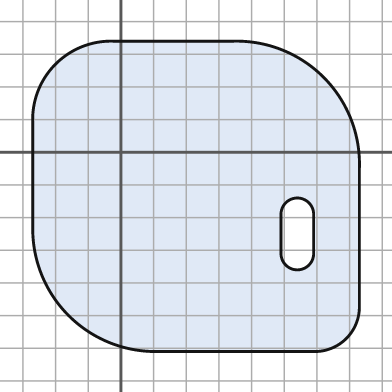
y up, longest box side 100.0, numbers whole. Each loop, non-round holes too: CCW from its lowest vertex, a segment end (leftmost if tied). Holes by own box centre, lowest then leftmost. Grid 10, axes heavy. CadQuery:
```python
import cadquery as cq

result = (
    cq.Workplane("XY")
    .moveTo(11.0, -61.0)
    .lineTo(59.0, -61.0)
    .threePointArc((69.0, -57.0), (73.0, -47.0))
    .lineTo(73.0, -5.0)
    .threePointArc((62.0, 23.0), (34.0, 34.0))
    .lineTo(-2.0, 34.0)
    .threePointArc((-20.0, 27.0), (-27.0, 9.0))
    .lineTo(-27.0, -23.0)
    .threePointArc((-16.0, -50.0), (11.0, -61.0))
    .close()
    .moveTo(49.0, -31.0)
    .threePointArc((54.0, -36.0), (59.0, -31.0))
    .lineTo(59.0, -19.0)
    .threePointArc((54.0, -14.0), (49.0, -19.0))
    .close()
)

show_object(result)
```